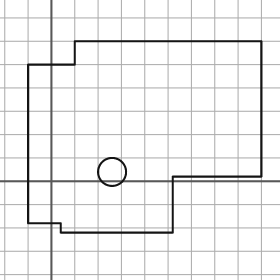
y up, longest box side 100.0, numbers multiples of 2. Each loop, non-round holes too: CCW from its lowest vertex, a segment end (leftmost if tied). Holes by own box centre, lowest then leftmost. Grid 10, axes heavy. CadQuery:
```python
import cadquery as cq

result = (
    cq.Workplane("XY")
    .moveTo(4.0, -22.0)
    .lineTo(52.0, -22.0)
    .lineTo(52.0, 2.0)
    .lineTo(90.0, 2.0)
    .lineTo(90.0, 60.0)
    .lineTo(10.0, 60.0)
    .lineTo(10.0, 50.0)
    .lineTo(-10.0, 50.0)
    .lineTo(-10.0, -18.0)
    .lineTo(4.0, -18.0)
    .close()
    .moveTo(26.0, 4.0)
    .circle(6.0)
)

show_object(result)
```